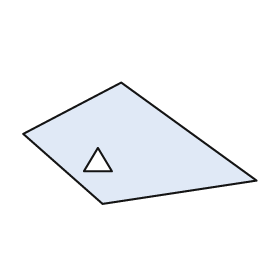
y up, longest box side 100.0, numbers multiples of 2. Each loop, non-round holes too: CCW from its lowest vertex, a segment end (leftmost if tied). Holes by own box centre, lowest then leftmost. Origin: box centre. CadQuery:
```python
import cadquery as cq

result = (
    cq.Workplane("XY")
    .moveTo(-16.0, -26.0)
    .lineTo(50.0, -16.0)
    .lineTo(-8.0, 26.0)
    .lineTo(-50.0, 4.0)
    .close()
    .moveTo(-24.0, -12.0)
    .lineTo(-12.0, -12.0)
    .lineTo(-18.0, -2.0)
    .close()
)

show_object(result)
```